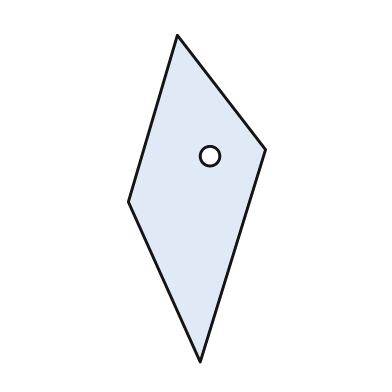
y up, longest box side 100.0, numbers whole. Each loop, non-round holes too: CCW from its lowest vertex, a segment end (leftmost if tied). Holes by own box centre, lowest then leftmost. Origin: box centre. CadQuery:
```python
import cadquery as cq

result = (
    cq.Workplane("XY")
    .moveTo(1.0, -50.0)
    .lineTo(21.0, 15.0)
    .lineTo(-6.0, 50.0)
    .lineTo(-21.0, -1.0)
    .close()
    .moveTo(4.0, 13.0)
    .circle(3.0)
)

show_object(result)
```